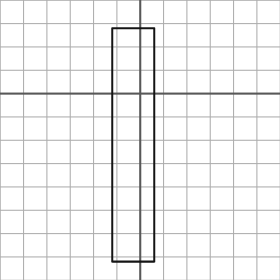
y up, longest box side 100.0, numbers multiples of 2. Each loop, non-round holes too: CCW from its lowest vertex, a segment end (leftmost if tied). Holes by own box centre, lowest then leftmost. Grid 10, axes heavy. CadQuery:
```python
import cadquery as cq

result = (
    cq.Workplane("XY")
    .moveTo(-12.0, -72.0)
    .lineTo(6.0, -72.0)
    .lineTo(6.0, 28.0)
    .lineTo(-12.0, 28.0)
    .close()
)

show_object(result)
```